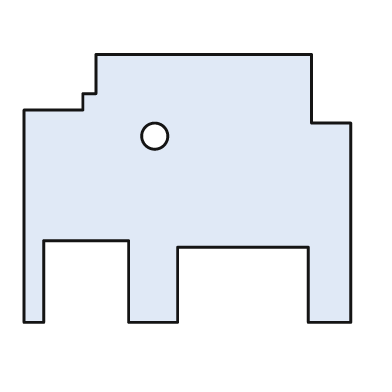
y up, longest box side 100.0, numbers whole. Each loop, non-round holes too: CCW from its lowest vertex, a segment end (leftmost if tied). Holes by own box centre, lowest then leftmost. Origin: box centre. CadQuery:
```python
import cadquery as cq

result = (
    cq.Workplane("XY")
    .moveTo(-50.0, -41.0)
    .lineTo(-44.0, -41.0)
    .lineTo(-44.0, -16.0)
    .lineTo(-18.0, -16.0)
    .lineTo(-18.0, -41.0)
    .lineTo(-3.0, -41.0)
    .lineTo(-3.0, -18.0)
    .lineTo(37.0, -18.0)
    .lineTo(37.0, -41.0)
    .lineTo(50.0, -41.0)
    .lineTo(50.0, 20.0)
    .lineTo(38.0, 20.0)
    .lineTo(38.0, 41.0)
    .lineTo(-28.0, 41.0)
    .lineTo(-28.0, 29.0)
    .lineTo(-32.0, 29.0)
    .lineTo(-32.0, 24.0)
    .lineTo(-50.0, 24.0)
    .close()
    .moveTo(-10.0, 16.0)
    .circle(4.0)
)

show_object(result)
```